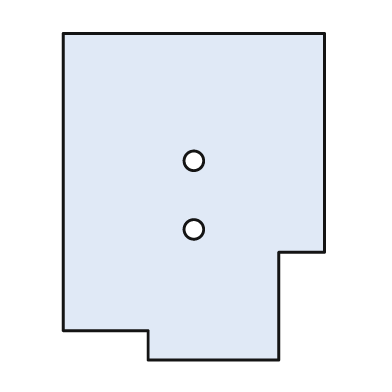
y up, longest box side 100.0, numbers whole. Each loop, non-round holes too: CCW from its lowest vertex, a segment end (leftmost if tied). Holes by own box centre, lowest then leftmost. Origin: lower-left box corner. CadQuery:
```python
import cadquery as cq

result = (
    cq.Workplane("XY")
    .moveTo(26.0, 0.0)
    .lineTo(66.0, 0.0)
    .lineTo(66.0, 33.0)
    .lineTo(80.0, 33.0)
    .lineTo(80.0, 100.0)
    .lineTo(0.0, 100.0)
    .lineTo(0.0, 9.0)
    .lineTo(26.0, 9.0)
    .close()
    .moveTo(40.0, 40.0)
    .circle(3.0)
    .moveTo(40.0, 61.0)
    .circle(3.0)
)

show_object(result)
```